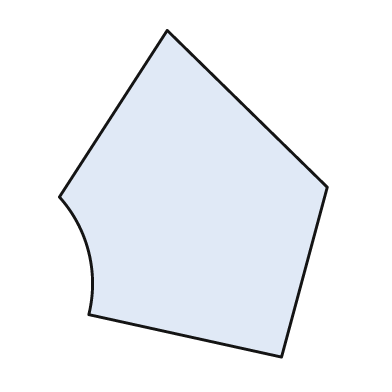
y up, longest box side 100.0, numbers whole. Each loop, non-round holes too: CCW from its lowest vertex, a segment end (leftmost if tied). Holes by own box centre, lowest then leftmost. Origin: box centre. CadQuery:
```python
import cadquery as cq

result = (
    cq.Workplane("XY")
    .moveTo(27.0, -50.0)
    .lineTo(41.0, 2.0)
    .lineTo(-8.0, 50.0)
    .lineTo(-41.0, -1.0)
    .threePointArc((-32.0, -18.0), (-32.0, -37.0))
    .close()
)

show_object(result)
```